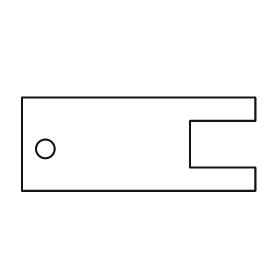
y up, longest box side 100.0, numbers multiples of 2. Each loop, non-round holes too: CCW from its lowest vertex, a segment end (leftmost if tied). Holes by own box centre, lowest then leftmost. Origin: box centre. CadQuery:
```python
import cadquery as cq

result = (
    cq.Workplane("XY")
    .moveTo(-50.0, -20.0)
    .lineTo(50.0, -20.0)
    .lineTo(50.0, -10.0)
    .lineTo(22.0, -10.0)
    .lineTo(22.0, 10.0)
    .lineTo(50.0, 10.0)
    .lineTo(50.0, 20.0)
    .lineTo(-50.0, 20.0)
    .close()
    .moveTo(-40.0, -2.0)
    .circle(4.0)
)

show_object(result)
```